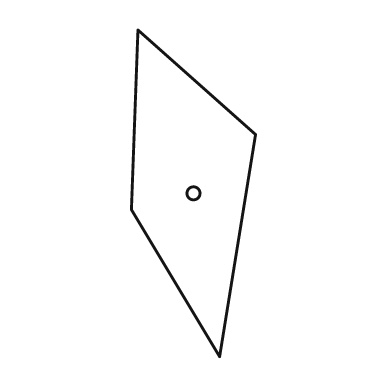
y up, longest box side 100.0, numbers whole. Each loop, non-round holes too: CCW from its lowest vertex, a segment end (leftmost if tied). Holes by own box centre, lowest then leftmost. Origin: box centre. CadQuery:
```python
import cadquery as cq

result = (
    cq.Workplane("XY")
    .moveTo(8.0, -50.0)
    .lineTo(19.0, 18.0)
    .lineTo(-17.0, 50.0)
    .lineTo(-19.0, -5.0)
    .close()
    .moveTo(0.0, 0.0)
    .circle(2.0)
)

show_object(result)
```